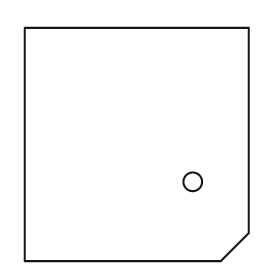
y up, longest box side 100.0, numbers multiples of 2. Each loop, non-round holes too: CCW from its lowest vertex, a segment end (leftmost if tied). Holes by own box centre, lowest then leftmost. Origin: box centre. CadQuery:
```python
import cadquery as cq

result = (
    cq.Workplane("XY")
    .moveTo(-48.0, -50.0)
    .lineTo(36.0, -50.0)
    .lineTo(48.0, -38.0)
    .lineTo(48.0, 50.0)
    .lineTo(-48.0, 50.0)
    .close()
    .moveTo(24.0, -16.0)
    .circle(4.0)
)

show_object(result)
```